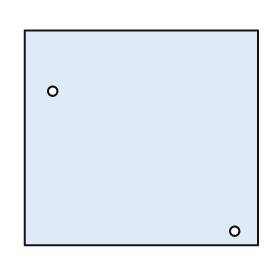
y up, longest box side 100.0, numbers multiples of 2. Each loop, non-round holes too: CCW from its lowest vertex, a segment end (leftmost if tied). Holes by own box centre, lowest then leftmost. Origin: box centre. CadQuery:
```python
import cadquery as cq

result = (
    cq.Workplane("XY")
    .moveTo(-50.0, -46.0)
    .lineTo(50.0, -46.0)
    .lineTo(50.0, 46.0)
    .lineTo(-50.0, 46.0)
    .close()
    .moveTo(40.0, -40.0)
    .circle(2.0)
    .moveTo(-38.0, 20.0)
    .circle(2.0)
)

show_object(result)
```